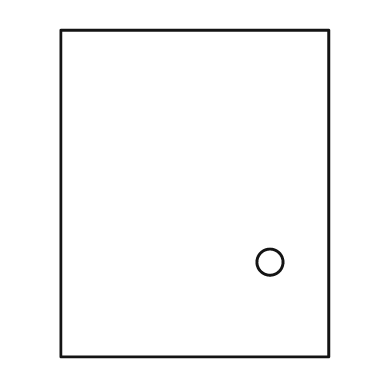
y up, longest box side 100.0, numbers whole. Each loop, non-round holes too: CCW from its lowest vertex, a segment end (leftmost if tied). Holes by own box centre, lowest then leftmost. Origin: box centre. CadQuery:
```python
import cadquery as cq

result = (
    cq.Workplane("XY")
    .moveTo(-41.0, -50.0)
    .lineTo(41.0, -50.0)
    .lineTo(41.0, 50.0)
    .lineTo(-41.0, 50.0)
    .close()
    .moveTo(23.0, -21.0)
    .circle(4.0)
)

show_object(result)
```